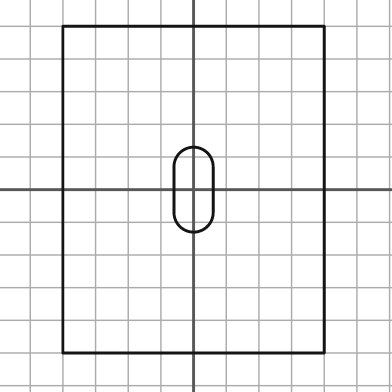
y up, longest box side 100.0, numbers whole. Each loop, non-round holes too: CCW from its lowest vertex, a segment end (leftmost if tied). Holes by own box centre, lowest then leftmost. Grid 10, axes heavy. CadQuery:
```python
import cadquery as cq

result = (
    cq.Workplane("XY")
    .moveTo(-40.0, -50.0)
    .lineTo(40.0, -50.0)
    .lineTo(40.0, 50.0)
    .lineTo(-40.0, 50.0)
    .close()
    .moveTo(-6.0, -7.0)
    .threePointArc((0.0, -13.0), (6.0, -7.0))
    .lineTo(6.0, 7.0)
    .threePointArc((0.0, 13.0), (-6.0, 7.0))
    .close()
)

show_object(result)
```